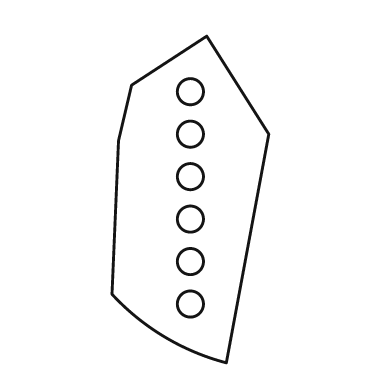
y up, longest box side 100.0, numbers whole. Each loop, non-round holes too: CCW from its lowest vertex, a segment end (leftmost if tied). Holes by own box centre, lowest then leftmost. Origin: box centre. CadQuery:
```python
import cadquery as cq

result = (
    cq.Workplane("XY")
    .moveTo(11.0, -50.0)
    .lineTo(24.0, 20.0)
    .lineTo(5.0, 50.0)
    .lineTo(-18.0, 35.0)
    .lineTo(-22.0, 18.0)
    .lineTo(-24.0, -29.0)
    .threePointArc((-8.0, -42.0), (11.0, -50.0))
    .close()
    .moveTo(0.0, -32.0)
    .circle(4.0)
    .moveTo(0.0, -19.0)
    .circle(4.0)
    .moveTo(0.0, -6.0)
    .circle(4.0)
    .moveTo(0.0, 7.0)
    .circle(4.0)
    .moveTo(0.0, 20.0)
    .circle(4.0)
    .moveTo(0.0, 33.0)
    .circle(4.0)
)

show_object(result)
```